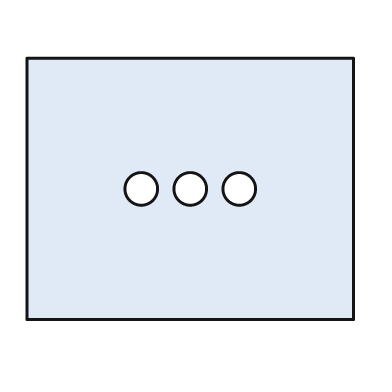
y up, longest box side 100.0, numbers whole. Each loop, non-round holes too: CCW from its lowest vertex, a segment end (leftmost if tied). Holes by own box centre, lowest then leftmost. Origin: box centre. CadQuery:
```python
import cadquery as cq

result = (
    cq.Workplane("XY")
    .moveTo(-50.0, -40.0)
    .lineTo(50.0, -40.0)
    .lineTo(50.0, 40.0)
    .lineTo(-50.0, 40.0)
    .close()
    .moveTo(-15.0, 0.0)
    .circle(5.0)
    .moveTo(0.0, 0.0)
    .circle(5.0)
    .moveTo(15.0, 0.0)
    .circle(5.0)
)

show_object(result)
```